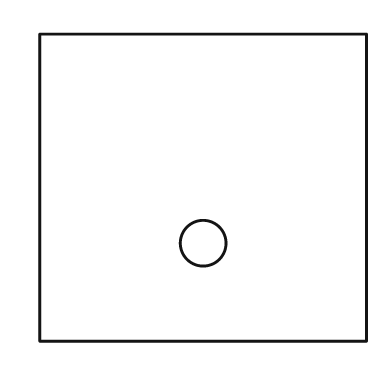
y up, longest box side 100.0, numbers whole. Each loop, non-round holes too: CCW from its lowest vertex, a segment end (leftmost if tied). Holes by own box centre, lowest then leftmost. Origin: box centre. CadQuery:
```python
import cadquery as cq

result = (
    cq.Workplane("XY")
    .moveTo(-50.0, -47.0)
    .lineTo(50.0, -47.0)
    .lineTo(50.0, 47.0)
    .lineTo(-50.0, 47.0)
    .close()
    .moveTo(0.0, -17.0)
    .circle(7.0)
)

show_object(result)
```